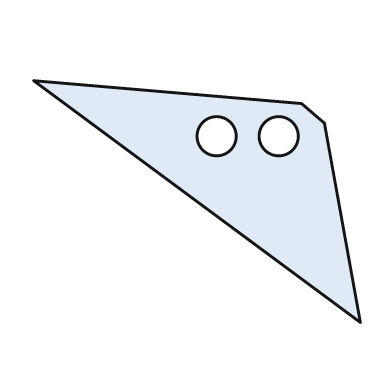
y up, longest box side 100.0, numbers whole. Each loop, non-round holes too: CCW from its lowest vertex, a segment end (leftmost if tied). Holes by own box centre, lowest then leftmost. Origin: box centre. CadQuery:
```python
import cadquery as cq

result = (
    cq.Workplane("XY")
    .moveTo(50.0, -37.0)
    .lineTo(39.0, 24.0)
    .lineTo(32.0, 30.0)
    .lineTo(-50.0, 37.0)
    .close()
    .moveTo(6.0, 20.0)
    .circle(6.0)
    .moveTo(25.0, 20.0)
    .circle(6.0)
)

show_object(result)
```